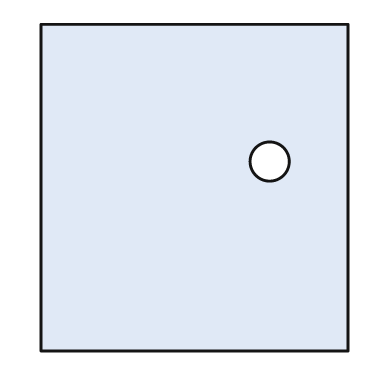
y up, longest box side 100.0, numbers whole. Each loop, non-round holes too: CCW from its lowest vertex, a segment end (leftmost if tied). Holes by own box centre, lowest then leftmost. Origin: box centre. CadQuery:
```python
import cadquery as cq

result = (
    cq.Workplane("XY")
    .moveTo(-47.0, -50.0)
    .lineTo(47.0, -50.0)
    .lineTo(47.0, 50.0)
    .lineTo(-47.0, 50.0)
    .close()
    .moveTo(23.0, 8.0)
    .circle(6.0)
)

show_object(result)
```